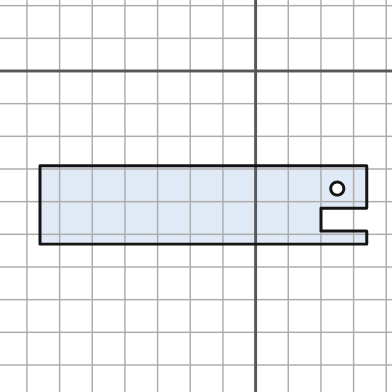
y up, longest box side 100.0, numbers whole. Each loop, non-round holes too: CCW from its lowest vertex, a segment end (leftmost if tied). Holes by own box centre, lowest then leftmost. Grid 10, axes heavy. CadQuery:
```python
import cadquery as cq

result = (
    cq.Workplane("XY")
    .moveTo(-66.0, -53.0)
    .lineTo(34.0, -53.0)
    .lineTo(34.0, -49.0)
    .lineTo(20.0, -49.0)
    .lineTo(20.0, -42.0)
    .lineTo(34.0, -42.0)
    .lineTo(34.0, -29.0)
    .lineTo(-66.0, -29.0)
    .close()
    .moveTo(25.0, -36.0)
    .circle(2.0)
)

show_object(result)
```